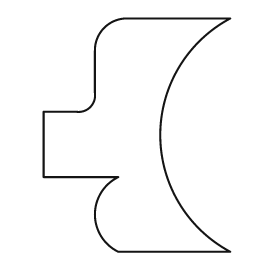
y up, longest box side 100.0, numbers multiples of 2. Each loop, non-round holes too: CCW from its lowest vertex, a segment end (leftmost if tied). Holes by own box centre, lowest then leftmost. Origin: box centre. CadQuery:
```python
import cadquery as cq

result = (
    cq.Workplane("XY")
    .moveTo(-8.0, -50.0)
    .lineTo(40.0, -50.0)
    .threePointArc((10.0, 0.0), (40.0, 50.0))
    .lineTo(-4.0, 50.0)
    .threePointArc((-14.0, 46.0), (-18.0, 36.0))
    .lineTo(-18.0, 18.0)
    .threePointArc((-20.0, 12.0), (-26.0, 10.0))
    .lineTo(-40.0, 10.0)
    .lineTo(-40.0, -18.0)
    .lineTo(-8.0, -18.0)
    .threePointArc((-18.0, -34.0), (-8.0, -50.0))
    .close()
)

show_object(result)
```